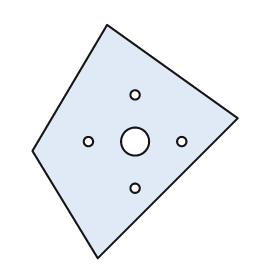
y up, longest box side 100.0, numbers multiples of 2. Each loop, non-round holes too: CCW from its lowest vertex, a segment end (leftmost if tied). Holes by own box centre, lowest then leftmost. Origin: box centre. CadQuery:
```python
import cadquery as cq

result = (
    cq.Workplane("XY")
    .moveTo(-16.0, -50.0)
    .lineTo(44.0, 10.0)
    .lineTo(-12.0, 50.0)
    .lineTo(-44.0, -4.0)
    .close()
    .moveTo(0.0, -20.0)
    .circle(2.0)
    .moveTo(-20.0, 0.0)
    .circle(2.0)
    .moveTo(0.0, 0.0)
    .circle(6.0)
    .moveTo(20.0, 0.0)
    .circle(2.0)
    .moveTo(0.0, 20.0)
    .circle(2.0)
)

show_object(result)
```